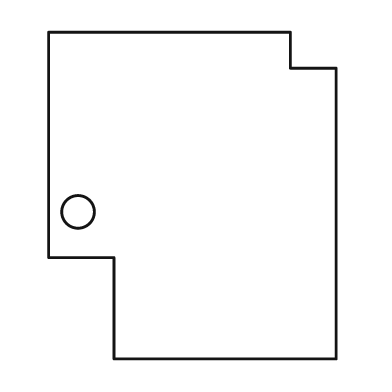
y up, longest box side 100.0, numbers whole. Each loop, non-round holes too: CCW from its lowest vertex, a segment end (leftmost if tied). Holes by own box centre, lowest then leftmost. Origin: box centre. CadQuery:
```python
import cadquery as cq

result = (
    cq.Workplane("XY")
    .moveTo(-24.0, -50.0)
    .lineTo(44.0, -50.0)
    .lineTo(44.0, 39.0)
    .lineTo(30.0, 39.0)
    .lineTo(30.0, 50.0)
    .lineTo(-44.0, 50.0)
    .lineTo(-44.0, -19.0)
    .lineTo(-24.0, -19.0)
    .close()
    .moveTo(-35.0, -5.0)
    .circle(5.0)
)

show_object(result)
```